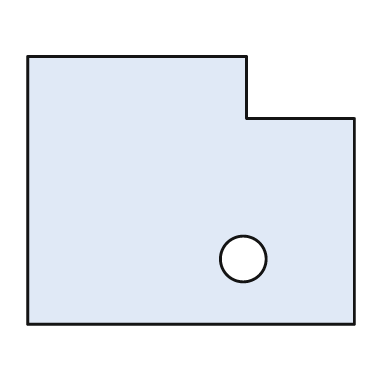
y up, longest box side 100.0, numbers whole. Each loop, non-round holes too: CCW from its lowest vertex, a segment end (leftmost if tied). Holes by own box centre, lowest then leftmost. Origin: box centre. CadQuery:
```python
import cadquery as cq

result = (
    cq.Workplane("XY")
    .moveTo(-50.0, -41.0)
    .lineTo(50.0, -41.0)
    .lineTo(50.0, 22.0)
    .lineTo(17.0, 22.0)
    .lineTo(17.0, 41.0)
    .lineTo(-50.0, 41.0)
    .close()
    .moveTo(16.0, -21.0)
    .circle(7.0)
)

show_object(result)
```